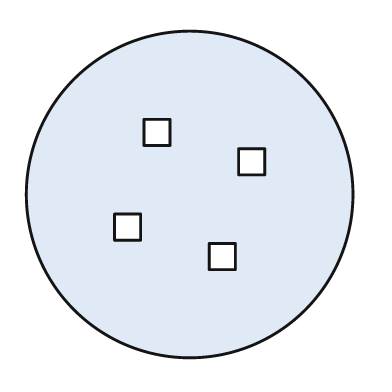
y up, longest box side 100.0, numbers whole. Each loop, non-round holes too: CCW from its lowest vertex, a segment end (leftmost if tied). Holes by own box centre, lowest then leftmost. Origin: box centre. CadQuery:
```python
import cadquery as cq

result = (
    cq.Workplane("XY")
    .moveTo(0.0, 0.0)
    .circle(50.0)
    .moveTo(6.0, -23.0)
    .lineTo(14.0, -23.0)
    .lineTo(14.0, -15.0)
    .lineTo(6.0, -15.0)
    .close()
    .moveTo(-23.0, -14.0)
    .lineTo(-15.0, -14.0)
    .lineTo(-15.0, -6.0)
    .lineTo(-23.0, -6.0)
    .close()
    .moveTo(15.0, 6.0)
    .lineTo(23.0, 6.0)
    .lineTo(23.0, 14.0)
    .lineTo(15.0, 14.0)
    .close()
    .moveTo(-14.0, 15.0)
    .lineTo(-6.0, 15.0)
    .lineTo(-6.0, 23.0)
    .lineTo(-14.0, 23.0)
    .close()
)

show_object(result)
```